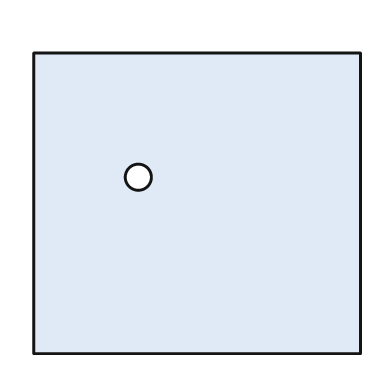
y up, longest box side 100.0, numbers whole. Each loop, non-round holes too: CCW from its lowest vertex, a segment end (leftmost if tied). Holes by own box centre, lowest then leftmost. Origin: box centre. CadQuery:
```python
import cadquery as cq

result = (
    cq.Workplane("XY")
    .moveTo(-50.0, -46.0)
    .lineTo(50.0, -46.0)
    .lineTo(50.0, 46.0)
    .lineTo(-50.0, 46.0)
    .close()
    .moveTo(-18.0, 8.0)
    .circle(4.0)
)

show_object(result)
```